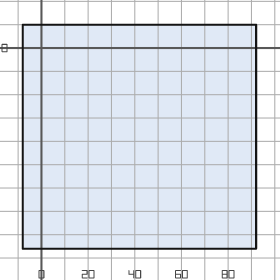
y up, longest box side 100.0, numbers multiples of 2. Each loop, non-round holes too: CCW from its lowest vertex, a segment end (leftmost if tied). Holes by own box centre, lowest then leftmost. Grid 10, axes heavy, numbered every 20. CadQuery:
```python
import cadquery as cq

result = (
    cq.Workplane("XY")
    .moveTo(-8.0, -86.0)
    .lineTo(92.0, -86.0)
    .lineTo(92.0, 10.0)
    .lineTo(-8.0, 10.0)
    .close()
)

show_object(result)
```